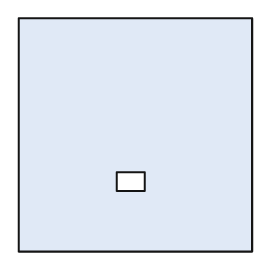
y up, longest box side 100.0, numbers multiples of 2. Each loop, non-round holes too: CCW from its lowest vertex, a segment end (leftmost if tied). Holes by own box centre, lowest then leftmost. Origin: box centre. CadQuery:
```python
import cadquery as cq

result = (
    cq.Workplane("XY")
    .moveTo(-50.0, -50.0)
    .lineTo(50.0, -50.0)
    .lineTo(50.0, 50.0)
    .lineTo(-50.0, 50.0)
    .close()
    .moveTo(-8.0, -24.0)
    .lineTo(4.0, -24.0)
    .lineTo(4.0, -16.0)
    .lineTo(-8.0, -16.0)
    .close()
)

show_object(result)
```